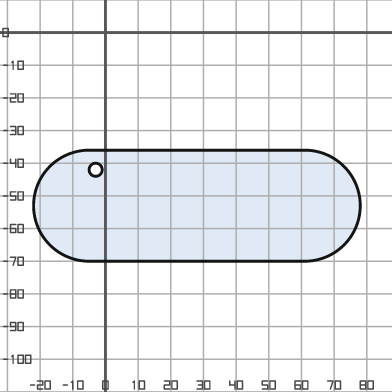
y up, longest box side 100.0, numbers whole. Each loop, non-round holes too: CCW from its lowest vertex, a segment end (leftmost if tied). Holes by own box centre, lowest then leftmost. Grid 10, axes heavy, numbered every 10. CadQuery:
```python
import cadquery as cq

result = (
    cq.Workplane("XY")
    .moveTo(-5.0, -70.0)
    .lineTo(61.0, -70.0)
    .threePointArc((78.0, -53.0), (61.0, -36.0))
    .lineTo(-5.0, -36.0)
    .threePointArc((-22.0, -53.0), (-5.0, -70.0))
    .close()
    .moveTo(-3.0, -42.0)
    .circle(2.0)
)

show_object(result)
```